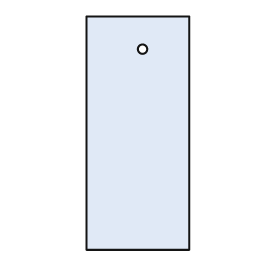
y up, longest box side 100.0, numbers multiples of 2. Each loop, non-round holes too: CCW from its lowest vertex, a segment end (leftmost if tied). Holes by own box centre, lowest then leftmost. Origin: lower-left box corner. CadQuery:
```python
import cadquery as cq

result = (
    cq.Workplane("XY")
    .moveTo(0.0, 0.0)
    .lineTo(44.0, 0.0)
    .lineTo(44.0, 100.0)
    .lineTo(0.0, 100.0)
    .close()
    .moveTo(24.0, 86.0)
    .circle(2.0)
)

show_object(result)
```